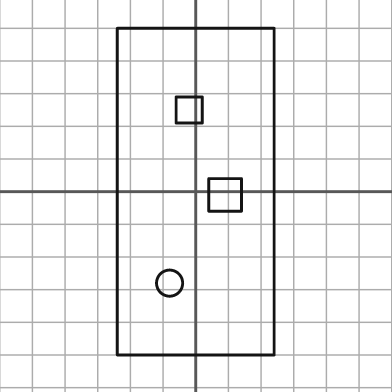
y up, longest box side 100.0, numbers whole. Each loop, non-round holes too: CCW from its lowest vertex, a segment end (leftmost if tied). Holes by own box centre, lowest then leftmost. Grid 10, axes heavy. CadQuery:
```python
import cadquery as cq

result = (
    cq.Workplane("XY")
    .moveTo(-24.0, -50.0)
    .lineTo(24.0, -50.0)
    .lineTo(24.0, 50.0)
    .lineTo(-24.0, 50.0)
    .close()
    .moveTo(-8.0, -28.0)
    .circle(4.0)
    .moveTo(4.0, -6.0)
    .lineTo(14.0, -6.0)
    .lineTo(14.0, 4.0)
    .lineTo(4.0, 4.0)
    .close()
    .moveTo(-6.0, 21.0)
    .lineTo(2.0, 21.0)
    .lineTo(2.0, 29.0)
    .lineTo(-6.0, 29.0)
    .close()
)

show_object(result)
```